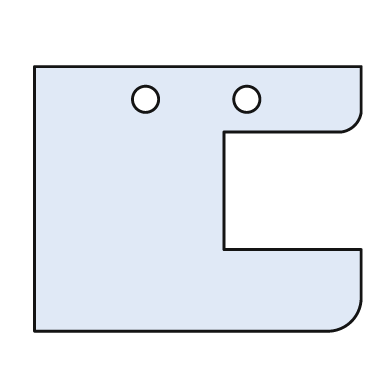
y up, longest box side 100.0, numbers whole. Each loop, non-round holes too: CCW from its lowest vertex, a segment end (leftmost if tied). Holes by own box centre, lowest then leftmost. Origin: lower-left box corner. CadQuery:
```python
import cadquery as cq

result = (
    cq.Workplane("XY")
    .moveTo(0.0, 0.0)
    .lineTo(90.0, 0.0)
    .threePointArc((97.0, 3.0), (100.0, 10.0))
    .lineTo(100.0, 25.0)
    .lineTo(58.0, 25.0)
    .lineTo(58.0, 61.0)
    .lineTo(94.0, 61.0)
    .threePointArc((98.0, 63.0), (100.0, 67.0))
    .lineTo(100.0, 81.0)
    .lineTo(0.0, 81.0)
    .close()
    .moveTo(34.0, 71.0)
    .circle(4.0)
    .moveTo(65.0, 71.0)
    .circle(4.0)
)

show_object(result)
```